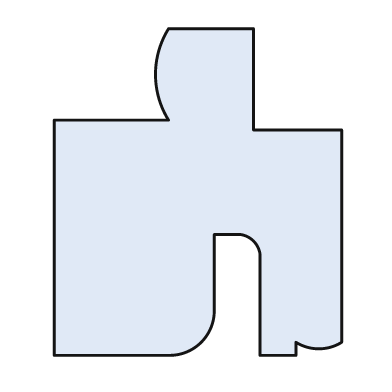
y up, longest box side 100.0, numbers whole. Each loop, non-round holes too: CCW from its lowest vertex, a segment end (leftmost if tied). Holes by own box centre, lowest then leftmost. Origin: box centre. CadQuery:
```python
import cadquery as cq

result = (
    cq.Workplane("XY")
    .moveTo(-44.0, -50.0)
    .lineTo(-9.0, -50.0)
    .threePointArc((1.0, -46.0), (5.0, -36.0))
    .lineTo(5.0, -13.0)
    .lineTo(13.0, -13.0)
    .threePointArc((17.0, -15.0), (19.0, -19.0))
    .lineTo(19.0, -50.0)
    .lineTo(30.0, -50.0)
    .lineTo(30.0, -46.0)
    .threePointArc((37.0, -48.0), (44.0, -46.0))
    .lineTo(44.0, 19.0)
    .lineTo(17.0, 19.0)
    .lineTo(17.0, 50.0)
    .lineTo(-9.0, 50.0)
    .threePointArc((-13.0, 36.0), (-9.0, 22.0))
    .lineTo(-44.0, 22.0)
    .close()
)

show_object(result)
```